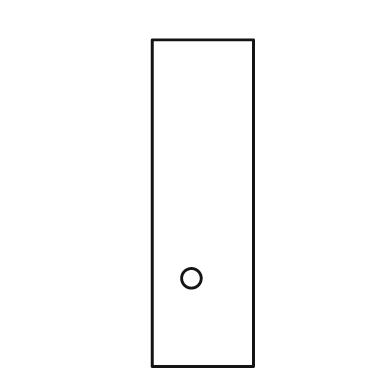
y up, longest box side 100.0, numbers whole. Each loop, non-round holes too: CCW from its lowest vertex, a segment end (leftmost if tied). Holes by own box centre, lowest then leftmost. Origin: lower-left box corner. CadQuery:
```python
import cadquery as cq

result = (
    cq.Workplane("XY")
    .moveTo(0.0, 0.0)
    .lineTo(31.0, 0.0)
    .lineTo(31.0, 100.0)
    .lineTo(0.0, 100.0)
    .close()
    .moveTo(12.0, 27.0)
    .circle(3.0)
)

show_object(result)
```